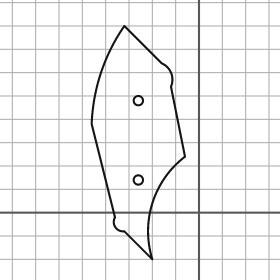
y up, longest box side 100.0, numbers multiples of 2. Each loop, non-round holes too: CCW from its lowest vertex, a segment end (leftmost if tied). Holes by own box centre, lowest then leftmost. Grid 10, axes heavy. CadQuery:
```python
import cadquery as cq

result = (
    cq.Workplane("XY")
    .moveTo(-20.0, -20.0)
    .threePointArc((-20.0, 4.0), (-6.0, 24.0))
    .lineTo(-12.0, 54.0)
    .threePointArc((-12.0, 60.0), (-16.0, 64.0))
    .lineTo(-32.0, 80.0)
    .threePointArc((-42.0, 60.0), (-46.0, 38.0))
    .lineTo(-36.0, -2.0)
    .threePointArc((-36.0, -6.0), (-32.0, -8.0))
    .close()
    .moveTo(-26.0, 14.0)
    .circle(2.0)
    .moveTo(-26.0, 48.0)
    .circle(2.0)
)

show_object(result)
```